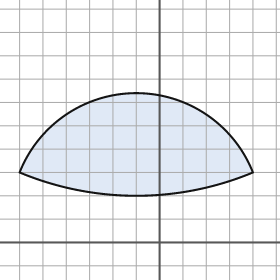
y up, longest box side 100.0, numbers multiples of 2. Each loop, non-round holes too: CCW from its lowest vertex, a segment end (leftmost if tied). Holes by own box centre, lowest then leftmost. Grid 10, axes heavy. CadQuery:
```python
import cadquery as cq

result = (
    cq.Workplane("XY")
    .moveTo(-60.0, 30.0)
    .threePointArc((-10.0, 20.0), (40.0, 30.0))
    .threePointArc((-10.0, 64.0), (-60.0, 30.0))
    .close()
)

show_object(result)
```